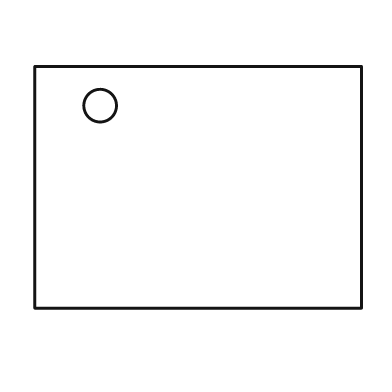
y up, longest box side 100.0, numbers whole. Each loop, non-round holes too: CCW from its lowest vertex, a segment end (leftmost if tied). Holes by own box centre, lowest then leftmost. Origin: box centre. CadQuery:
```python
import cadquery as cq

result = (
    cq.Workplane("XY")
    .moveTo(-50.0, -37.0)
    .lineTo(50.0, -37.0)
    .lineTo(50.0, 37.0)
    .lineTo(-50.0, 37.0)
    .close()
    .moveTo(-30.0, 25.0)
    .circle(5.0)
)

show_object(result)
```